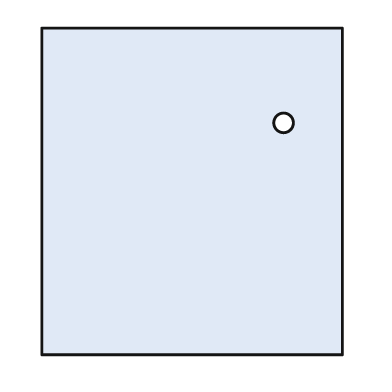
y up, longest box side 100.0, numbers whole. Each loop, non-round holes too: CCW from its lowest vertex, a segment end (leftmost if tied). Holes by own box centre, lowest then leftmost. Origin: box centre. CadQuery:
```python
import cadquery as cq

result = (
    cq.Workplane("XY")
    .moveTo(-46.0, -50.0)
    .lineTo(46.0, -50.0)
    .lineTo(46.0, 50.0)
    .lineTo(-46.0, 50.0)
    .close()
    .moveTo(28.0, 21.0)
    .circle(3.0)
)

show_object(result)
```